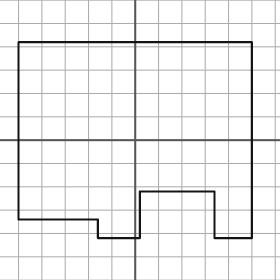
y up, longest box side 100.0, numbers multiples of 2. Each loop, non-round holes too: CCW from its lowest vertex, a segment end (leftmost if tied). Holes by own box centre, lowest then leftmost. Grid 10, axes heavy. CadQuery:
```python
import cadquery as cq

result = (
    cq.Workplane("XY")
    .moveTo(-16.0, -42.0)
    .lineTo(2.0, -42.0)
    .lineTo(2.0, -22.0)
    .lineTo(34.0, -22.0)
    .lineTo(34.0, -42.0)
    .lineTo(50.0, -42.0)
    .lineTo(50.0, 42.0)
    .lineTo(-50.0, 42.0)
    .lineTo(-50.0, -34.0)
    .lineTo(-16.0, -34.0)
    .close()
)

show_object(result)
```